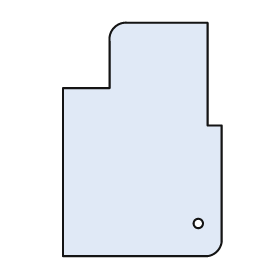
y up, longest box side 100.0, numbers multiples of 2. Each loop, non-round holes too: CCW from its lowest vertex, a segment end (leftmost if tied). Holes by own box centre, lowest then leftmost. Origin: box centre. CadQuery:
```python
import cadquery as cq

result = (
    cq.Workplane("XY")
    .moveTo(-34.0, -50.0)
    .lineTo(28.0, -50.0)
    .threePointArc((32.0, -48.0), (34.0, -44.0))
    .lineTo(34.0, 6.0)
    .lineTo(28.0, 6.0)
    .lineTo(28.0, 50.0)
    .lineTo(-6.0, 50.0)
    .threePointArc((-12.0, 48.0), (-14.0, 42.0))
    .lineTo(-14.0, 22.0)
    .lineTo(-34.0, 22.0)
    .close()
    .moveTo(24.0, -36.0)
    .circle(2.0)
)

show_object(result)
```